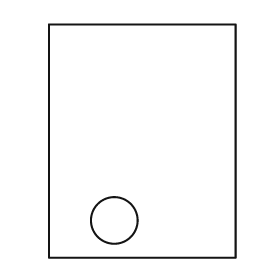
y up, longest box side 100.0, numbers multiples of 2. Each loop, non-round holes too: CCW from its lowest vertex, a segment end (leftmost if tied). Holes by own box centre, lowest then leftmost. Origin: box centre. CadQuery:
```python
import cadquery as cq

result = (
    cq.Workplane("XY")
    .moveTo(-40.0, -50.0)
    .lineTo(40.0, -50.0)
    .lineTo(40.0, 50.0)
    .lineTo(-40.0, 50.0)
    .close()
    .moveTo(-12.0, -34.0)
    .circle(10.0)
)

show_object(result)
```